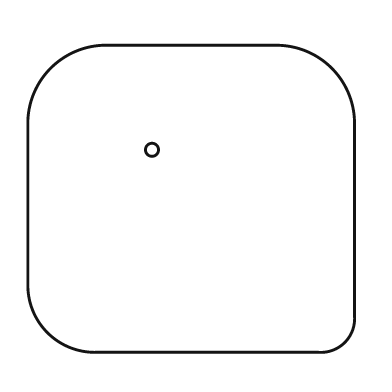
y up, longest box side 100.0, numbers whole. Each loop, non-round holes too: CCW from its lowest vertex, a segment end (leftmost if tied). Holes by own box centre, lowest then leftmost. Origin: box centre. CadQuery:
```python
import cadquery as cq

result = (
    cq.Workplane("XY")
    .moveTo(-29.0, -47.0)
    .lineTo(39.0, -47.0)
    .threePointArc((47.0, -44.0), (50.0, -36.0))
    .lineTo(50.0, 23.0)
    .threePointArc((43.0, 40.0), (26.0, 47.0))
    .lineTo(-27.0, 47.0)
    .threePointArc((-43.0, 40.0), (-50.0, 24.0))
    .lineTo(-50.0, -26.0)
    .threePointArc((-44.0, -41.0), (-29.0, -47.0))
    .close()
    .moveTo(-12.0, 15.0)
    .circle(2.0)
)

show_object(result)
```